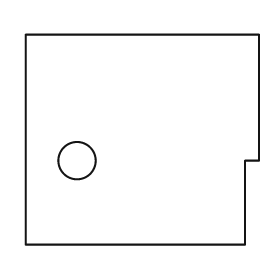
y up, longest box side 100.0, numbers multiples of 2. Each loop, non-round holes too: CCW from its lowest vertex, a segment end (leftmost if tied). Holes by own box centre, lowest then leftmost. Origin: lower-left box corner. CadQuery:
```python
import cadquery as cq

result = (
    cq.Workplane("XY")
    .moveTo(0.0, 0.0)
    .lineTo(94.0, 0.0)
    .lineTo(94.0, 36.0)
    .lineTo(100.0, 36.0)
    .lineTo(100.0, 90.0)
    .lineTo(0.0, 90.0)
    .close()
    .moveTo(22.0, 36.0)
    .circle(8.0)
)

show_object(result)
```